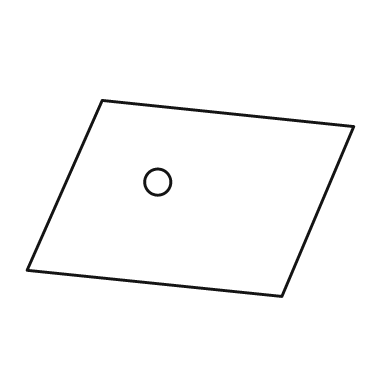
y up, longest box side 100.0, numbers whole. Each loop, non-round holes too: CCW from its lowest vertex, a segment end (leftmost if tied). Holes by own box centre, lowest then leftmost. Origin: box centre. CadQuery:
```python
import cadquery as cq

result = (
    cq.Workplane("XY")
    .moveTo(28.0, -30.0)
    .lineTo(50.0, 22.0)
    .lineTo(-27.0, 30.0)
    .lineTo(-50.0, -22.0)
    .close()
    .moveTo(-10.0, 5.0)
    .circle(4.0)
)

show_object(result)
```